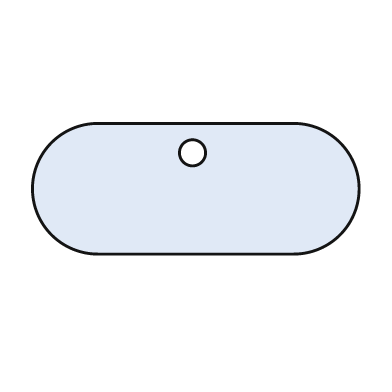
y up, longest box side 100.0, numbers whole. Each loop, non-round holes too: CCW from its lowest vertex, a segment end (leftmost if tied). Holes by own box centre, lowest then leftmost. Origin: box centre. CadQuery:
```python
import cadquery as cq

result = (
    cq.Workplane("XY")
    .moveTo(-30.0, -20.0)
    .lineTo(30.0, -20.0)
    .threePointArc((50.0, 0.0), (30.0, 20.0))
    .lineTo(-30.0, 20.0)
    .threePointArc((-50.0, 0.0), (-30.0, -20.0))
    .close()
    .moveTo(-1.0, 11.0)
    .circle(4.0)
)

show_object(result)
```